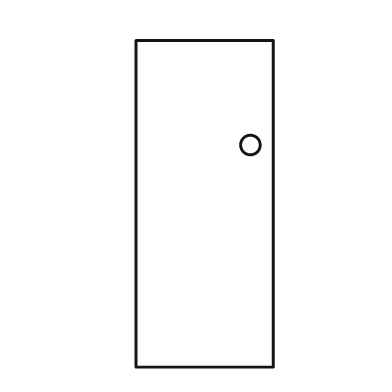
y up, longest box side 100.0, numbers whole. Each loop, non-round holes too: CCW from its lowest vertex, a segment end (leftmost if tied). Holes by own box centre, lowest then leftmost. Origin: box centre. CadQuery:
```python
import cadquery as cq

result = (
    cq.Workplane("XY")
    .moveTo(-21.0, -50.0)
    .lineTo(21.0, -50.0)
    .lineTo(21.0, 50.0)
    .lineTo(-21.0, 50.0)
    .close()
    .moveTo(14.0, 18.0)
    .circle(3.0)
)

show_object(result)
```